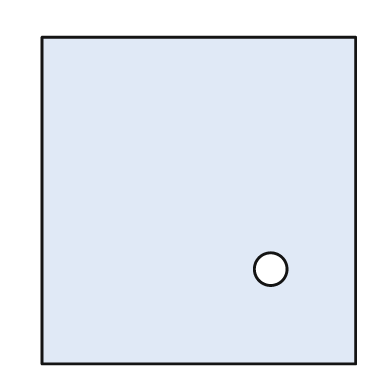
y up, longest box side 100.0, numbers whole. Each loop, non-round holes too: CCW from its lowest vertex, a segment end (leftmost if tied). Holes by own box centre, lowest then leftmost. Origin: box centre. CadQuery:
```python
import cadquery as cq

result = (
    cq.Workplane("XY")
    .moveTo(-48.0, -50.0)
    .lineTo(48.0, -50.0)
    .lineTo(48.0, 50.0)
    .lineTo(-48.0, 50.0)
    .close()
    .moveTo(22.0, -21.0)
    .circle(5.0)
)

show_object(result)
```